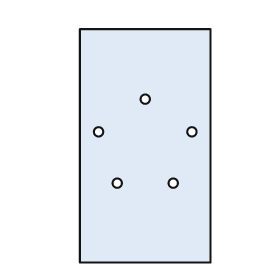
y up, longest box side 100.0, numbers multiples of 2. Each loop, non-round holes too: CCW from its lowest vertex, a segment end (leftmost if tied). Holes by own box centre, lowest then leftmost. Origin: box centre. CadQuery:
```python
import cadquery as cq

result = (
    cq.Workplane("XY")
    .moveTo(-28.0, -50.0)
    .lineTo(28.0, -50.0)
    .lineTo(28.0, 50.0)
    .lineTo(-28.0, 50.0)
    .close()
    .moveTo(-12.0, -16.0)
    .circle(2.0)
    .moveTo(12.0, -16.0)
    .circle(2.0)
    .moveTo(-20.0, 6.0)
    .circle(2.0)
    .moveTo(20.0, 6.0)
    .circle(2.0)
    .moveTo(0.0, 20.0)
    .circle(2.0)
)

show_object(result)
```